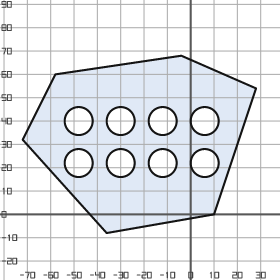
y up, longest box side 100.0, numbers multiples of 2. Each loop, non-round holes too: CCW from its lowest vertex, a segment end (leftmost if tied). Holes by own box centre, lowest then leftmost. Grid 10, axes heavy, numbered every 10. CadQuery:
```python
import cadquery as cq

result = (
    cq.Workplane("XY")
    .moveTo(-36.0, -8.0)
    .lineTo(10.0, 0.0)
    .lineTo(28.0, 54.0)
    .lineTo(-4.0, 68.0)
    .lineTo(-58.0, 60.0)
    .lineTo(-72.0, 32.0)
    .close()
    .moveTo(-48.0, 22.0)
    .circle(6.0)
    .moveTo(-30.0, 22.0)
    .circle(6.0)
    .moveTo(-12.0, 22.0)
    .circle(6.0)
    .moveTo(6.0, 22.0)
    .circle(6.0)
    .moveTo(-48.0, 40.0)
    .circle(6.0)
    .moveTo(-30.0, 40.0)
    .circle(6.0)
    .moveTo(-12.0, 40.0)
    .circle(6.0)
    .moveTo(6.0, 40.0)
    .circle(6.0)
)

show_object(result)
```